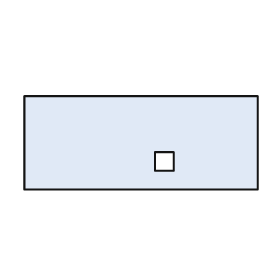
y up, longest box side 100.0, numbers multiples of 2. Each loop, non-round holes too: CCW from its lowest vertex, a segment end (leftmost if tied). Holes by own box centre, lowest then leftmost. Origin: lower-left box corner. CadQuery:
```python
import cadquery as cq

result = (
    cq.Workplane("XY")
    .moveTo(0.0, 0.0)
    .lineTo(100.0, 0.0)
    .lineTo(100.0, 40.0)
    .lineTo(0.0, 40.0)
    .close()
    .moveTo(56.0, 8.0)
    .lineTo(64.0, 8.0)
    .lineTo(64.0, 16.0)
    .lineTo(56.0, 16.0)
    .close()
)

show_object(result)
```